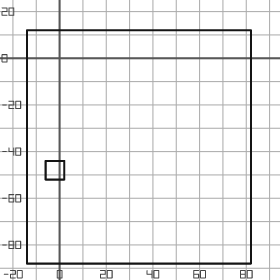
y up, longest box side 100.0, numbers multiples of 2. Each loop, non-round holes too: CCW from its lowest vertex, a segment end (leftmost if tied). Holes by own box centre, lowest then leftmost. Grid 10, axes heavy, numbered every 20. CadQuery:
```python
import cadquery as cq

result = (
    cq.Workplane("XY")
    .moveTo(-14.0, -88.0)
    .lineTo(82.0, -88.0)
    .lineTo(82.0, 12.0)
    .lineTo(-14.0, 12.0)
    .close()
    .moveTo(-6.0, -52.0)
    .lineTo(2.0, -52.0)
    .lineTo(2.0, -44.0)
    .lineTo(-6.0, -44.0)
    .close()
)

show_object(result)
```